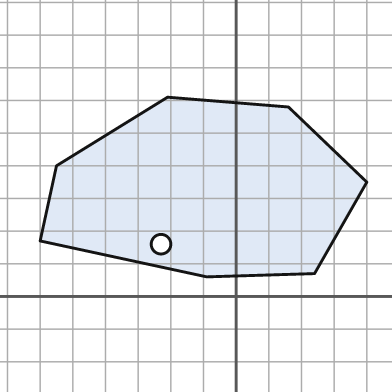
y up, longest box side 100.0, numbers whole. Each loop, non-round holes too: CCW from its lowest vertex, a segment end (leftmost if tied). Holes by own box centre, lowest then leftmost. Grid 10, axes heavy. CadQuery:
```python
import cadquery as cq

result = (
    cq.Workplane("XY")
    .moveTo(-9.0, 6.0)
    .lineTo(24.0, 7.0)
    .lineTo(40.0, 35.0)
    .lineTo(16.0, 58.0)
    .lineTo(-21.0, 61.0)
    .lineTo(-55.0, 40.0)
    .lineTo(-60.0, 17.0)
    .close()
    .moveTo(-23.0, 16.0)
    .circle(3.0)
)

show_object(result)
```